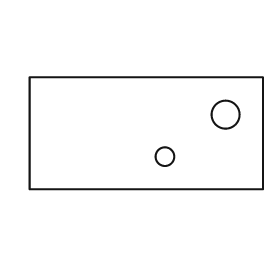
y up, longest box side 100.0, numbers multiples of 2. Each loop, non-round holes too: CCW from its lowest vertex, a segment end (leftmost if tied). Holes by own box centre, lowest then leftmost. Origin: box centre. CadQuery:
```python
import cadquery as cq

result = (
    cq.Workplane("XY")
    .moveTo(-50.0, -24.0)
    .lineTo(50.0, -24.0)
    .lineTo(50.0, 24.0)
    .lineTo(-50.0, 24.0)
    .close()
    .moveTo(8.0, -10.0)
    .circle(4.0)
    .moveTo(34.0, 8.0)
    .circle(6.0)
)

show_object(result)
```